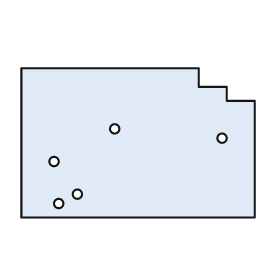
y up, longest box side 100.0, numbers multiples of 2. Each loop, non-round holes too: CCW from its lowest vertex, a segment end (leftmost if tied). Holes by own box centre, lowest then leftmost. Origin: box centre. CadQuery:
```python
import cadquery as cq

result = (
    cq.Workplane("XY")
    .moveTo(-50.0, -32.0)
    .lineTo(50.0, -32.0)
    .lineTo(50.0, 18.0)
    .lineTo(38.0, 18.0)
    .lineTo(38.0, 24.0)
    .lineTo(26.0, 24.0)
    .lineTo(26.0, 32.0)
    .lineTo(-50.0, 32.0)
    .close()
    .moveTo(-34.0, -26.0)
    .circle(2.0)
    .moveTo(-26.0, -22.0)
    .circle(2.0)
    .moveTo(-36.0, -8.0)
    .circle(2.0)
    .moveTo(36.0, 2.0)
    .circle(2.0)
    .moveTo(-10.0, 6.0)
    .circle(2.0)
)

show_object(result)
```